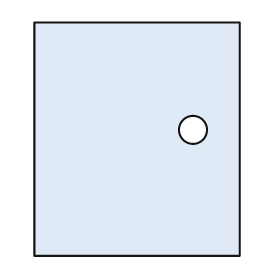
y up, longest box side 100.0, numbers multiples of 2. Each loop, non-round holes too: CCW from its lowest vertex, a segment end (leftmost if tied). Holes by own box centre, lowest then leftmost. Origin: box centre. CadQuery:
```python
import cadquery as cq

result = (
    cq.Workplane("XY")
    .moveTo(-44.0, -50.0)
    .lineTo(44.0, -50.0)
    .lineTo(44.0, 50.0)
    .lineTo(-44.0, 50.0)
    .close()
    .moveTo(24.0, 4.0)
    .circle(6.0)
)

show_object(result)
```